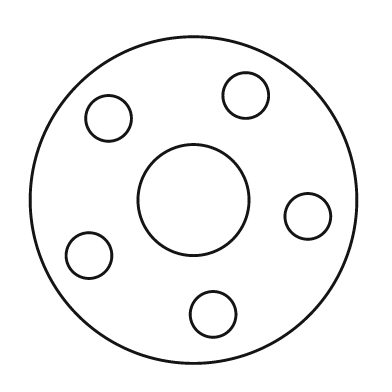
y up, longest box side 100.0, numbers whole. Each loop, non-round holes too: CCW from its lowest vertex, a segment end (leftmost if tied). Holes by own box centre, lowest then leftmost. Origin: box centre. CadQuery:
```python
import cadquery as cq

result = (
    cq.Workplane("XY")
    .moveTo(0.0, 0.0)
    .circle(50.0)
    .moveTo(6.0, -35.0)
    .circle(7.0)
    .moveTo(-32.0, -17.0)
    .circle(7.0)
    .moveTo(35.0, -5.0)
    .circle(7.0)
    .moveTo(0.0, 0.0)
    .circle(17.0)
    .moveTo(-26.0, 25.0)
    .circle(7.0)
    .moveTo(16.0, 32.0)
    .circle(7.0)
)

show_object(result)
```